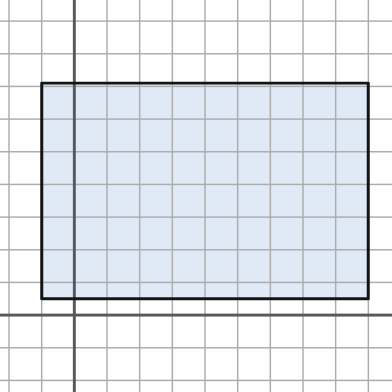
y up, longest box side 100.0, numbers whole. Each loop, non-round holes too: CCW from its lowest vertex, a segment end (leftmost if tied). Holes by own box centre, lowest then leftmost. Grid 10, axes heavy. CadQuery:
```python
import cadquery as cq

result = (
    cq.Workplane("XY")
    .moveTo(-10.0, 5.0)
    .lineTo(90.0, 5.0)
    .lineTo(90.0, 71.0)
    .lineTo(-10.0, 71.0)
    .close()
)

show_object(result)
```